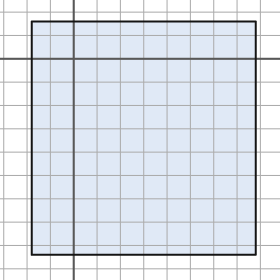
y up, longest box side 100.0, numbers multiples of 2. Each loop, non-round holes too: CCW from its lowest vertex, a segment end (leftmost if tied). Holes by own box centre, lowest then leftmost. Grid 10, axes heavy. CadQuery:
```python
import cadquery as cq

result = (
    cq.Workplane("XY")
    .moveTo(-18.0, -84.0)
    .lineTo(78.0, -84.0)
    .lineTo(78.0, 16.0)
    .lineTo(-18.0, 16.0)
    .close()
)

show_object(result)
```